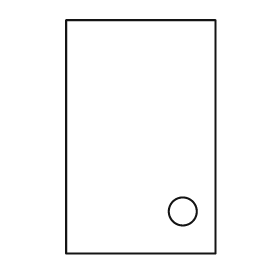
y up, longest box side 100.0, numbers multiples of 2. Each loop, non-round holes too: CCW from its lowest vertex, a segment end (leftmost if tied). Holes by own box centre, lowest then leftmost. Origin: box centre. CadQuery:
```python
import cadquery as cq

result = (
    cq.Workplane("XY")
    .moveTo(-32.0, -50.0)
    .lineTo(32.0, -50.0)
    .lineTo(32.0, 50.0)
    .lineTo(-32.0, 50.0)
    .close()
    .moveTo(18.0, -32.0)
    .circle(6.0)
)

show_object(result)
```